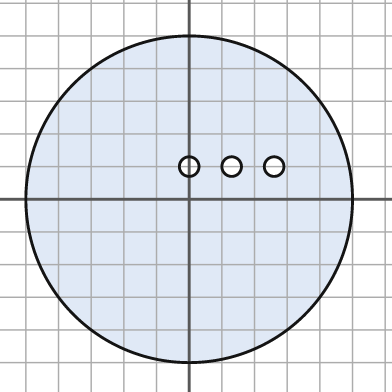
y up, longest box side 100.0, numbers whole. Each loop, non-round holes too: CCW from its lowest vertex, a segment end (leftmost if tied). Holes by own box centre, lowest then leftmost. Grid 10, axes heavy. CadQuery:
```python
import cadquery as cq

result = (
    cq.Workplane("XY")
    .moveTo(0.0, 0.0)
    .circle(50.0)
    .moveTo(0.0, 10.0)
    .circle(3.0)
    .moveTo(13.0, 10.0)
    .circle(3.0)
    .moveTo(26.0, 10.0)
    .circle(3.0)
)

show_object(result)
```